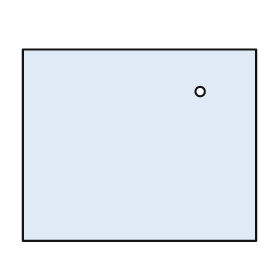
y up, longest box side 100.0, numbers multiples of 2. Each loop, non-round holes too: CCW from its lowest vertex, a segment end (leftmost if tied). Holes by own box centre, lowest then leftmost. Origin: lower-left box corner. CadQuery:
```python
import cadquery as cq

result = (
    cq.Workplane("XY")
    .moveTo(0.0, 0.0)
    .lineTo(100.0, 0.0)
    .lineTo(100.0, 82.0)
    .lineTo(0.0, 82.0)
    .close()
    .moveTo(76.0, 64.0)
    .circle(2.0)
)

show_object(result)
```